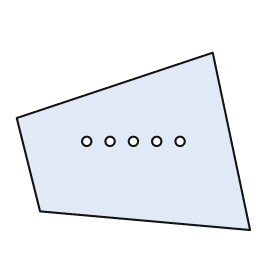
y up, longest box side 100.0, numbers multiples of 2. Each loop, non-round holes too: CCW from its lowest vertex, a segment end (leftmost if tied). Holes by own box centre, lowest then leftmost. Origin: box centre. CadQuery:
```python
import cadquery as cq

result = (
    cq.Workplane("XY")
    .moveTo(50.0, -38.0)
    .lineTo(34.0, 38.0)
    .lineTo(-50.0, 10.0)
    .lineTo(-40.0, -30.0)
    .close()
    .moveTo(-20.0, 0.0)
    .circle(2.0)
    .moveTo(-10.0, 0.0)
    .circle(2.0)
    .moveTo(0.0, 0.0)
    .circle(2.0)
    .moveTo(10.0, 0.0)
    .circle(2.0)
    .moveTo(20.0, 0.0)
    .circle(2.0)
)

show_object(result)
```